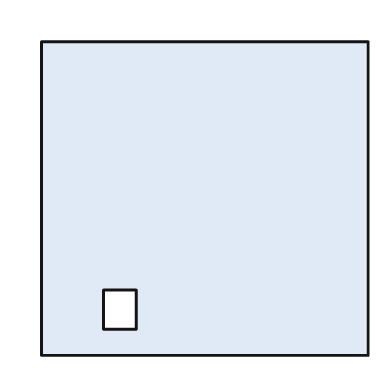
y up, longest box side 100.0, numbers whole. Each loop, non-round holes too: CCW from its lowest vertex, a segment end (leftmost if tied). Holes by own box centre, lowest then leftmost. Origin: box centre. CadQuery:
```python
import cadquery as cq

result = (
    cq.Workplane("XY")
    .moveTo(-50.0, -48.0)
    .lineTo(50.0, -48.0)
    .lineTo(50.0, 48.0)
    .lineTo(-50.0, 48.0)
    .close()
    .moveTo(-31.0, -40.0)
    .lineTo(-21.0, -40.0)
    .lineTo(-21.0, -28.0)
    .lineTo(-31.0, -28.0)
    .close()
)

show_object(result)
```